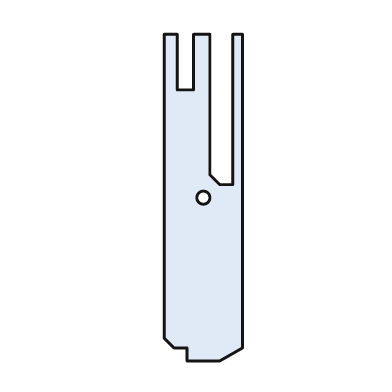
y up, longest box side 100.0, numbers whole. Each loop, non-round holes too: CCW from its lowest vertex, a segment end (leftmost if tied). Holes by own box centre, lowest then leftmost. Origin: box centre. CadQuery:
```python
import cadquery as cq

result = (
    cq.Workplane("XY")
    .moveTo(-5.0, -50.0)
    .lineTo(5.0, -50.0)
    .lineTo(12.0, -46.0)
    .lineTo(12.0, 50.0)
    .lineTo(9.0, 50.0)
    .lineTo(9.0, 4.0)
    .lineTo(5.0, 4.0)
    .lineTo(2.0, 7.0)
    .lineTo(2.0, 50.0)
    .lineTo(-3.0, 50.0)
    .lineTo(-3.0, 33.0)
    .lineTo(-8.0, 33.0)
    .lineTo(-8.0, 50.0)
    .lineTo(-12.0, 50.0)
    .lineTo(-12.0, -43.0)
    .lineTo(-9.0, -46.0)
    .lineTo(-5.0, -46.0)
    .close()
    .moveTo(0.0, 0.0)
    .circle(2.0)
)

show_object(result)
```